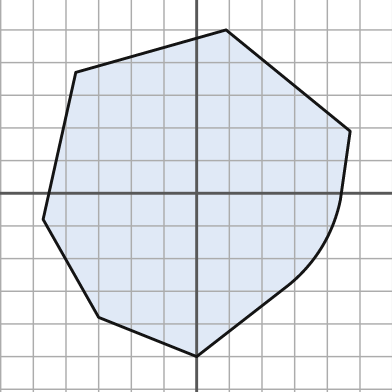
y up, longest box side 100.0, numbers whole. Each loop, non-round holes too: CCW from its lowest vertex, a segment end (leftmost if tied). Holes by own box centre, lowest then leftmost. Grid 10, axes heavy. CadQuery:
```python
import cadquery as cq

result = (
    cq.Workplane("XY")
    .moveTo(0.0, -50.0)
    .lineTo(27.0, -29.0)
    .threePointArc((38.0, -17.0), (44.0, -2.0))
    .lineTo(47.0, 19.0)
    .lineTo(9.0, 50.0)
    .lineTo(-37.0, 37.0)
    .lineTo(-47.0, -8.0)
    .lineTo(-30.0, -38.0)
    .close()
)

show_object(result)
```